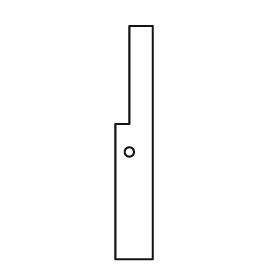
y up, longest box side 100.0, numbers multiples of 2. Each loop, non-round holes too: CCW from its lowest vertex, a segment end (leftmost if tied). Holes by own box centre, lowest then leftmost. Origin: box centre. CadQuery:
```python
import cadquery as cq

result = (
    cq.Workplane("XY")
    .moveTo(-8.0, -50.0)
    .lineTo(8.0, -50.0)
    .lineTo(8.0, 50.0)
    .lineTo(-2.0, 50.0)
    .lineTo(-2.0, 8.0)
    .lineTo(-8.0, 8.0)
    .close()
    .moveTo(-2.0, -4.0)
    .circle(2.0)
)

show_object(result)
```